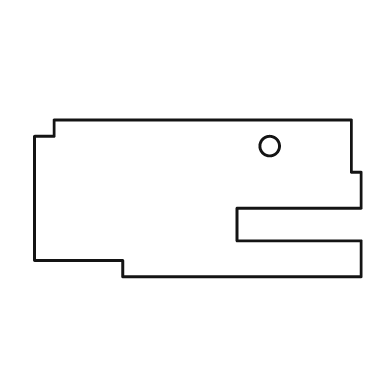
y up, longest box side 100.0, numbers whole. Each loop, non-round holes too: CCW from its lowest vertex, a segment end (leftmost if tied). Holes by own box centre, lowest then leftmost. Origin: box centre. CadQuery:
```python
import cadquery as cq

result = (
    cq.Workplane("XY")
    .moveTo(-23.0, -24.0)
    .lineTo(50.0, -24.0)
    .lineTo(50.0, -13.0)
    .lineTo(12.0, -13.0)
    .lineTo(12.0, -3.0)
    .lineTo(50.0, -3.0)
    .lineTo(50.0, 8.0)
    .lineTo(47.0, 8.0)
    .lineTo(47.0, 24.0)
    .lineTo(-44.0, 24.0)
    .lineTo(-44.0, 19.0)
    .lineTo(-50.0, 19.0)
    .lineTo(-50.0, -19.0)
    .lineTo(-23.0, -19.0)
    .close()
    .moveTo(22.0, 16.0)
    .circle(3.0)
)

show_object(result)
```